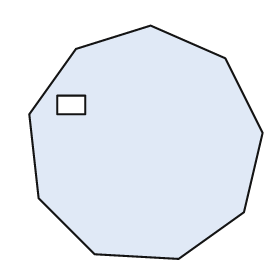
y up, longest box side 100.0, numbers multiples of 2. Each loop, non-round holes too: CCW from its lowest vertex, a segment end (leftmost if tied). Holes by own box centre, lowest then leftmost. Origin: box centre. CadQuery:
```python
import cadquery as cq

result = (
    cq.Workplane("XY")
    .moveTo(14.0, -50.0)
    .lineTo(42.0, -30.0)
    .lineTo(50.0, 4.0)
    .lineTo(34.0, 36.0)
    .lineTo(2.0, 50.0)
    .lineTo(-30.0, 40.0)
    .lineTo(-50.0, 12.0)
    .lineTo(-46.0, -24.0)
    .lineTo(-22.0, -48.0)
    .close()
    .moveTo(-38.0, 12.0)
    .lineTo(-26.0, 12.0)
    .lineTo(-26.0, 20.0)
    .lineTo(-38.0, 20.0)
    .close()
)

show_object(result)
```